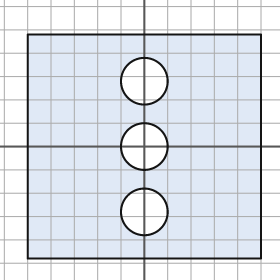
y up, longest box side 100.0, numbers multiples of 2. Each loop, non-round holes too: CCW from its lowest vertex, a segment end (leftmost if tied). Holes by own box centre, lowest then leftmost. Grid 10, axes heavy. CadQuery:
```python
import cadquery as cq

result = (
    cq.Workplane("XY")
    .moveTo(-50.0, -48.0)
    .lineTo(50.0, -48.0)
    .lineTo(50.0, 48.0)
    .lineTo(-50.0, 48.0)
    .close()
    .moveTo(0.0, -28.0)
    .circle(10.0)
    .moveTo(0.0, 0.0)
    .circle(10.0)
    .moveTo(0.0, 28.0)
    .circle(10.0)
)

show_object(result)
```